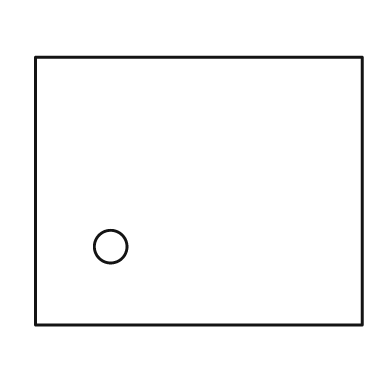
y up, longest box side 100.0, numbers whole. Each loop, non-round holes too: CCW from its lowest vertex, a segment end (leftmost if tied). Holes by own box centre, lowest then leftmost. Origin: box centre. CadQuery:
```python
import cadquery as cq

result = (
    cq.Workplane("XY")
    .moveTo(-50.0, -41.0)
    .lineTo(50.0, -41.0)
    .lineTo(50.0, 41.0)
    .lineTo(-50.0, 41.0)
    .close()
    .moveTo(-27.0, -17.0)
    .circle(5.0)
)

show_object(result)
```